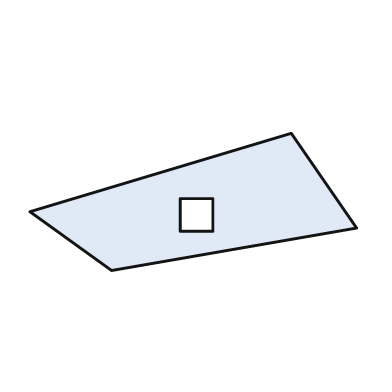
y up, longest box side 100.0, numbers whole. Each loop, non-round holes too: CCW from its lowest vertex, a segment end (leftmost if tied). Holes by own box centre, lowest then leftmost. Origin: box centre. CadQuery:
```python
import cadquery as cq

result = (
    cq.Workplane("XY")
    .moveTo(-25.0, -21.0)
    .lineTo(50.0, -8.0)
    .lineTo(30.0, 21.0)
    .lineTo(-50.0, -3.0)
    .close()
    .moveTo(-4.0, -9.0)
    .lineTo(6.0, -9.0)
    .lineTo(6.0, 1.0)
    .lineTo(-4.0, 1.0)
    .close()
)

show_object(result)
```